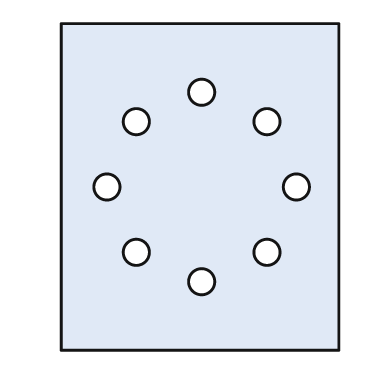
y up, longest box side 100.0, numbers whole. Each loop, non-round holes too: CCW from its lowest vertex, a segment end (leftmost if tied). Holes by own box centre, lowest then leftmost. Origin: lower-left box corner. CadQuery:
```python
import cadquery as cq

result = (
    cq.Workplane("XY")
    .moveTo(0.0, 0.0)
    .lineTo(85.0, 0.0)
    .lineTo(85.0, 100.0)
    .lineTo(0.0, 100.0)
    .close()
    .moveTo(43.0, 21.0)
    .circle(4.0)
    .moveTo(23.0, 30.0)
    .circle(4.0)
    .moveTo(63.0, 30.0)
    .circle(4.0)
    .moveTo(14.0, 50.0)
    .circle(4.0)
    .moveTo(72.0, 50.0)
    .circle(4.0)
    .moveTo(23.0, 70.0)
    .circle(4.0)
    .moveTo(63.0, 70.0)
    .circle(4.0)
    .moveTo(43.0, 79.0)
    .circle(4.0)
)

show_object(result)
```